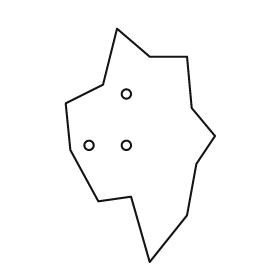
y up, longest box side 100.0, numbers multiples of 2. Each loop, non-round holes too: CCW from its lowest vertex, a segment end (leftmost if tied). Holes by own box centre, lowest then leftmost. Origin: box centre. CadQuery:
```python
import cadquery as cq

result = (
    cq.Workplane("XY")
    .moveTo(4.0, -50.0)
    .lineTo(20.0, -30.0)
    .lineTo(24.0, -8.0)
    .lineTo(32.0, 4.0)
    .lineTo(22.0, 16.0)
    .lineTo(20.0, 38.0)
    .lineTo(4.0, 38.0)
    .lineTo(-10.0, 50.0)
    .lineTo(-16.0, 26.0)
    .lineTo(-32.0, 18.0)
    .lineTo(-30.0, -2.0)
    .lineTo(-18.0, -24.0)
    .lineTo(-4.0, -22.0)
    .close()
    .moveTo(-22.0, 0.0)
    .circle(2.0)
    .moveTo(-6.0, 0.0)
    .circle(2.0)
    .moveTo(-6.0, 22.0)
    .circle(2.0)
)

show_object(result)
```